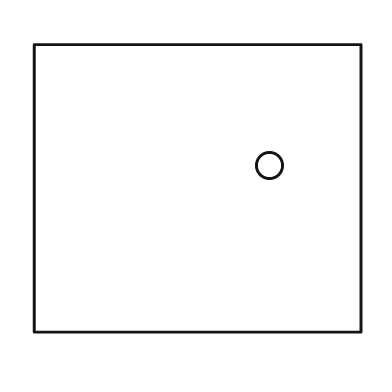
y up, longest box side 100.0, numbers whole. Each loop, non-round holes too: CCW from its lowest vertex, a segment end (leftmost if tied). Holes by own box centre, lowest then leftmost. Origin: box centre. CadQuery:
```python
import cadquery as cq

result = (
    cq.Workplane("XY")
    .moveTo(-50.0, -44.0)
    .lineTo(50.0, -44.0)
    .lineTo(50.0, 44.0)
    .lineTo(-50.0, 44.0)
    .close()
    .moveTo(22.0, 7.0)
    .circle(4.0)
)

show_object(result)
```